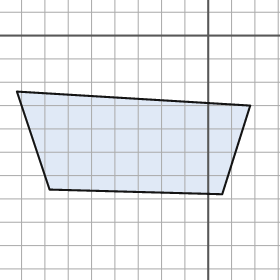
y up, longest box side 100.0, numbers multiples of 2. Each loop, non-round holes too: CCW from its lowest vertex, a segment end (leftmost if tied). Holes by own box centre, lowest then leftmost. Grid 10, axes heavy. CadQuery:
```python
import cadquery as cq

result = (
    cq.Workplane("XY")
    .moveTo(6.0, -68.0)
    .lineTo(18.0, -30.0)
    .lineTo(-82.0, -24.0)
    .lineTo(-68.0, -66.0)
    .close()
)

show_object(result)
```